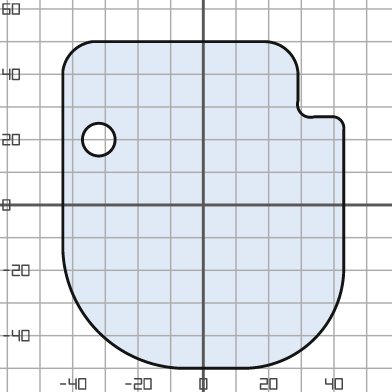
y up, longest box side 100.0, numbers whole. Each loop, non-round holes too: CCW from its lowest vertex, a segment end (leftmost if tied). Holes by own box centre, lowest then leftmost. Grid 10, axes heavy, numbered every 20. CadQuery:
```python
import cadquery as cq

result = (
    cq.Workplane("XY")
    .moveTo(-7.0, -50.0)
    .lineTo(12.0, -50.0)
    .threePointArc((34.0, -41.0), (43.0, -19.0))
    .lineTo(43.0, 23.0)
    .threePointArc((42.0, 26.0), (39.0, 27.0))
    .lineTo(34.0, 27.0)
    .threePointArc((30.0, 28.0), (29.0, 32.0))
    .lineTo(29.0, 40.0)
    .threePointArc((26.0, 47.0), (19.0, 50.0))
    .lineTo(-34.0, 50.0)
    .threePointArc((-40.0, 47.0), (-43.0, 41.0))
    .lineTo(-43.0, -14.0)
    .threePointArc((-32.0, -39.0), (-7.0, -50.0))
    .close()
    .moveTo(-32.0, 20.0)
    .circle(5.0)
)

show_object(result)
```